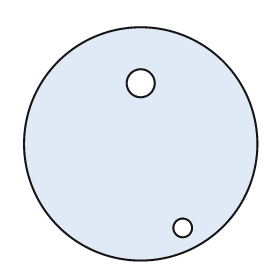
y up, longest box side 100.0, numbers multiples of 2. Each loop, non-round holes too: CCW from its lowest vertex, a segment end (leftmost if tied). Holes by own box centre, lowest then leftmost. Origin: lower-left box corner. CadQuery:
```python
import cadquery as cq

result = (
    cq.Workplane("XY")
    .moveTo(50.0, 50.0)
    .circle(50.0)
    .moveTo(68.0, 14.0)
    .circle(4.0)
    .moveTo(50.0, 76.0)
    .circle(6.0)
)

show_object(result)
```